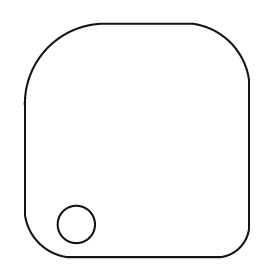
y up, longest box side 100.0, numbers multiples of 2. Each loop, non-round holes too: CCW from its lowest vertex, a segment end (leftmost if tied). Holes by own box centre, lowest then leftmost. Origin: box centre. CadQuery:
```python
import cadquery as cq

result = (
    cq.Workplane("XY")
    .moveTo(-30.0, -50.0)
    .lineTo(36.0, -50.0)
    .threePointArc((44.0, -46.0), (48.0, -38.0))
    .lineTo(48.0, 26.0)
    .threePointArc((40.0, 42.0), (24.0, 50.0))
    .lineTo(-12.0, 50.0)
    .threePointArc((-38.0, 40.0), (-48.0, 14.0))
    .lineTo(-48.0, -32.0)
    .threePointArc((-42.0, -44.0), (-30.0, -50.0))
    .close()
    .moveTo(-26.0, -36.0)
    .circle(8.0)
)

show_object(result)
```